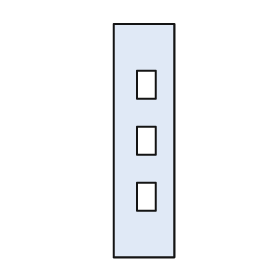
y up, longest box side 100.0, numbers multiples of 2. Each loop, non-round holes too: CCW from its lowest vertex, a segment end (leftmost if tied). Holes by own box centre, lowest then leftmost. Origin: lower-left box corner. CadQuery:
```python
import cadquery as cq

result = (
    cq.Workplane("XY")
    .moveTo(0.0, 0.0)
    .lineTo(26.0, 0.0)
    .lineTo(26.0, 100.0)
    .lineTo(0.0, 100.0)
    .close()
    .moveTo(10.0, 20.0)
    .lineTo(18.0, 20.0)
    .lineTo(18.0, 32.0)
    .lineTo(10.0, 32.0)
    .close()
    .moveTo(10.0, 44.0)
    .lineTo(18.0, 44.0)
    .lineTo(18.0, 56.0)
    .lineTo(10.0, 56.0)
    .close()
    .moveTo(10.0, 68.0)
    .lineTo(18.0, 68.0)
    .lineTo(18.0, 80.0)
    .lineTo(10.0, 80.0)
    .close()
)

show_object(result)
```